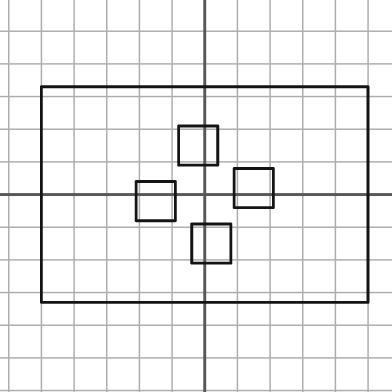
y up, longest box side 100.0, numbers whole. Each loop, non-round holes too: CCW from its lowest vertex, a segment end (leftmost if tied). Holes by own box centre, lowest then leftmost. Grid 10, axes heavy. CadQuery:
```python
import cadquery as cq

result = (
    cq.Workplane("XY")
    .moveTo(-50.0, -33.0)
    .lineTo(50.0, -33.0)
    .lineTo(50.0, 33.0)
    .lineTo(-50.0, 33.0)
    .close()
    .moveTo(-4.0, -21.0)
    .lineTo(8.0, -21.0)
    .lineTo(8.0, -9.0)
    .lineTo(-4.0, -9.0)
    .close()
    .moveTo(-21.0, -8.0)
    .lineTo(-9.0, -8.0)
    .lineTo(-9.0, 4.0)
    .lineTo(-21.0, 4.0)
    .close()
    .moveTo(9.0, -4.0)
    .lineTo(21.0, -4.0)
    .lineTo(21.0, 8.0)
    .lineTo(9.0, 8.0)
    .close()
    .moveTo(-8.0, 9.0)
    .lineTo(4.0, 9.0)
    .lineTo(4.0, 21.0)
    .lineTo(-8.0, 21.0)
    .close()
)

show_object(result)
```